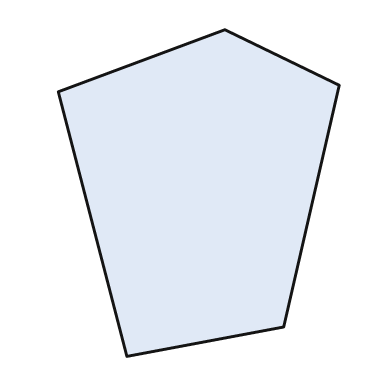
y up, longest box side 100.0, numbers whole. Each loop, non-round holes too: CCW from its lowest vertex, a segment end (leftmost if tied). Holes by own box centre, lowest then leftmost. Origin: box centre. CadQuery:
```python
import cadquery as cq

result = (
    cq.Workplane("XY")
    .moveTo(-22.0, -50.0)
    .lineTo(26.0, -41.0)
    .lineTo(43.0, 33.0)
    .lineTo(8.0, 50.0)
    .lineTo(-43.0, 31.0)
    .close()
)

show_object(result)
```